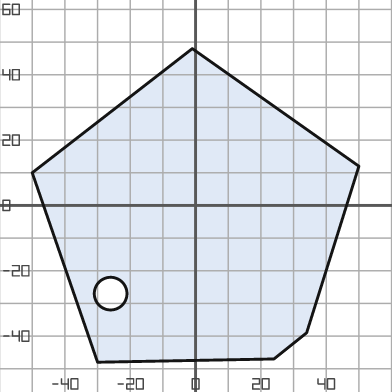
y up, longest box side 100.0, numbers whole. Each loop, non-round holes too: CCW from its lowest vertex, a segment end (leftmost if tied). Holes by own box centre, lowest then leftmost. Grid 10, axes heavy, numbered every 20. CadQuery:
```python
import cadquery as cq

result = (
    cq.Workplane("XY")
    .moveTo(-30.0, -48.0)
    .lineTo(24.0, -47.0)
    .lineTo(34.0, -39.0)
    .lineTo(50.0, 12.0)
    .lineTo(-1.0, 48.0)
    .lineTo(-50.0, 10.0)
    .close()
    .moveTo(-26.0, -27.0)
    .circle(5.0)
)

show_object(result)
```